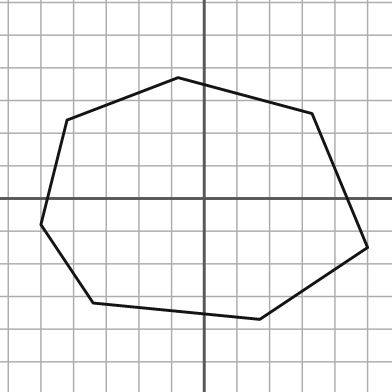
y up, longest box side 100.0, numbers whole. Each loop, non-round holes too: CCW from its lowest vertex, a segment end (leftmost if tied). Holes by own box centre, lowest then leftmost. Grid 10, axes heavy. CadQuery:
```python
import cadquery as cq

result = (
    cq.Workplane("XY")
    .moveTo(17.0, -37.0)
    .lineTo(50.0, -15.0)
    .lineTo(33.0, 26.0)
    .lineTo(-8.0, 37.0)
    .lineTo(-42.0, 24.0)
    .lineTo(-50.0, -8.0)
    .lineTo(-34.0, -32.0)
    .close()
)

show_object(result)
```